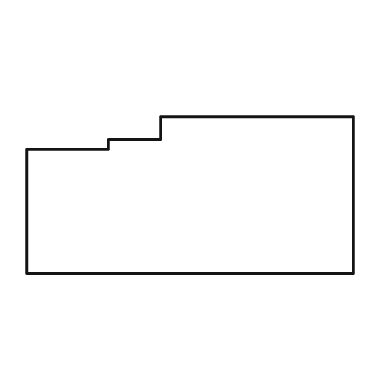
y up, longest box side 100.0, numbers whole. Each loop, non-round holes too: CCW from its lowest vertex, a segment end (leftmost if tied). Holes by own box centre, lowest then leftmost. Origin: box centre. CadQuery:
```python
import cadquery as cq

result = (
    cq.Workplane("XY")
    .moveTo(-50.0, -24.0)
    .lineTo(50.0, -24.0)
    .lineTo(50.0, 24.0)
    .lineTo(-9.0, 24.0)
    .lineTo(-9.0, 17.0)
    .lineTo(-25.0, 17.0)
    .lineTo(-25.0, 14.0)
    .lineTo(-50.0, 14.0)
    .close()
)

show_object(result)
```